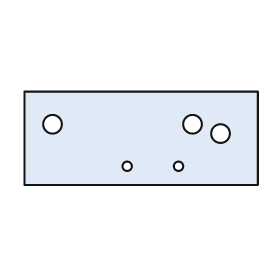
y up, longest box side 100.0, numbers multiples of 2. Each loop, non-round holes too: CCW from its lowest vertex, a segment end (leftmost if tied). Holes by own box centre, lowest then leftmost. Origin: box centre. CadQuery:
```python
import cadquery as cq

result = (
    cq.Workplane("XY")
    .moveTo(-50.0, -20.0)
    .lineTo(50.0, -20.0)
    .lineTo(50.0, 20.0)
    .lineTo(-50.0, 20.0)
    .close()
    .moveTo(-6.0, -12.0)
    .circle(2.0)
    .moveTo(16.0, -12.0)
    .circle(2.0)
    .moveTo(34.0, 2.0)
    .circle(4.0)
    .moveTo(-38.0, 6.0)
    .circle(4.0)
    .moveTo(22.0, 6.0)
    .circle(4.0)
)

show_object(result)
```